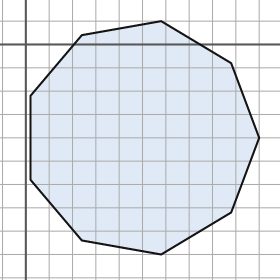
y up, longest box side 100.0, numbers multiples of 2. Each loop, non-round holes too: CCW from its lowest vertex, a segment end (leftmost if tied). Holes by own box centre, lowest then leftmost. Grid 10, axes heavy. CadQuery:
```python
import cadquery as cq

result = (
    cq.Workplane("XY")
    .moveTo(58.0, -90.0)
    .lineTo(88.0, -72.0)
    .lineTo(100.0, -40.0)
    .lineTo(88.0, -8.0)
    .lineTo(58.0, 10.0)
    .lineTo(24.0, 4.0)
    .lineTo(2.0, -22.0)
    .lineTo(2.0, -58.0)
    .lineTo(24.0, -84.0)
    .close()
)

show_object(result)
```